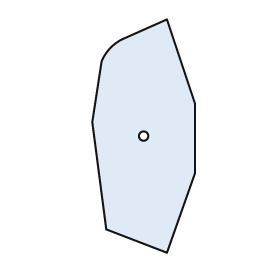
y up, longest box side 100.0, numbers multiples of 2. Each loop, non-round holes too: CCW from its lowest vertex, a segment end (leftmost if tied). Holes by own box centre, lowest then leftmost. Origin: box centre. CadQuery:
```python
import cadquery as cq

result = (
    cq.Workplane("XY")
    .moveTo(10.0, -50.0)
    .lineTo(22.0, -16.0)
    .lineTo(22.0, 14.0)
    .lineTo(10.0, 50.0)
    .lineTo(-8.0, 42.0)
    .threePointArc((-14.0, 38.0), (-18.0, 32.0))
    .lineTo(-22.0, 6.0)
    .lineTo(-16.0, -40.0)
    .close()
    .moveTo(0.0, 0.0)
    .circle(2.0)
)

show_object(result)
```